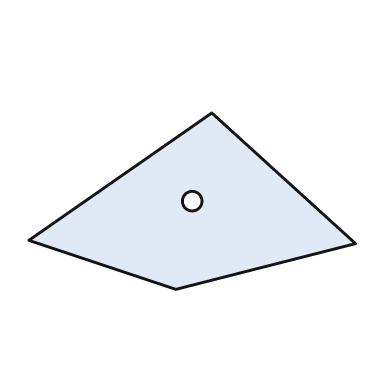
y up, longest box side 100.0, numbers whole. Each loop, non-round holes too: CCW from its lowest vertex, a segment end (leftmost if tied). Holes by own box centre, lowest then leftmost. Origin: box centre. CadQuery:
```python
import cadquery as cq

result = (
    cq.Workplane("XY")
    .moveTo(-5.0, -27.0)
    .lineTo(50.0, -13.0)
    .lineTo(6.0, 27.0)
    .lineTo(-50.0, -12.0)
    .close()
    .moveTo(0.0, 0.0)
    .circle(3.0)
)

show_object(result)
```